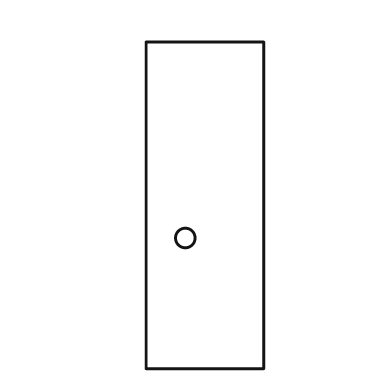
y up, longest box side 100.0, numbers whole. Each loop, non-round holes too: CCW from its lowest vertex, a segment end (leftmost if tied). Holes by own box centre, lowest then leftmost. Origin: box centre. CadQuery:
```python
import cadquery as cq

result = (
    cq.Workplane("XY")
    .moveTo(-18.0, -50.0)
    .lineTo(18.0, -50.0)
    .lineTo(18.0, 50.0)
    .lineTo(-18.0, 50.0)
    .close()
    .moveTo(-6.0, -10.0)
    .circle(3.0)
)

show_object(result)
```